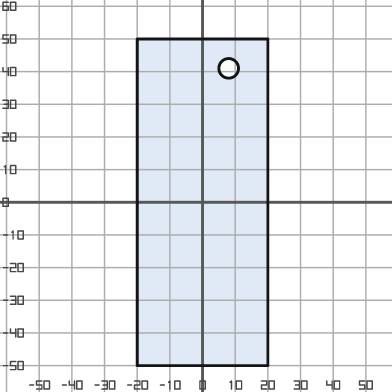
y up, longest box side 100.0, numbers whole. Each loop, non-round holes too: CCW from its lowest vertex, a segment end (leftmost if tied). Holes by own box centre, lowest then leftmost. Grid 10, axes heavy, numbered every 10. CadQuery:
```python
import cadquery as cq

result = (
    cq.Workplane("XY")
    .moveTo(-20.0, -50.0)
    .lineTo(20.0, -50.0)
    .lineTo(20.0, 50.0)
    .lineTo(-20.0, 50.0)
    .close()
    .moveTo(8.0, 41.0)
    .circle(3.0)
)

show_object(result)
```